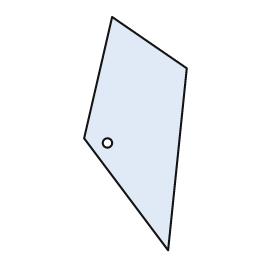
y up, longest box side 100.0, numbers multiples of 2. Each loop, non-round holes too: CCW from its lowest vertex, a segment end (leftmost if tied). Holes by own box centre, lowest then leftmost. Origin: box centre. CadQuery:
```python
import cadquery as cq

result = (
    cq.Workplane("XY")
    .moveTo(14.0, -50.0)
    .lineTo(22.0, 28.0)
    .lineTo(-10.0, 50.0)
    .lineTo(-22.0, -2.0)
    .close()
    .moveTo(-12.0, -4.0)
    .circle(2.0)
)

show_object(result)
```